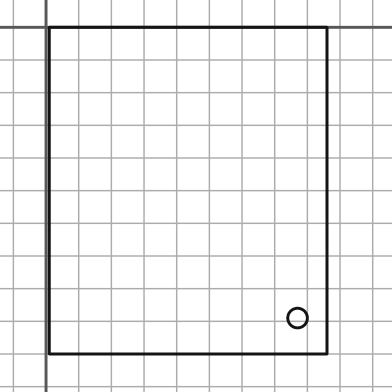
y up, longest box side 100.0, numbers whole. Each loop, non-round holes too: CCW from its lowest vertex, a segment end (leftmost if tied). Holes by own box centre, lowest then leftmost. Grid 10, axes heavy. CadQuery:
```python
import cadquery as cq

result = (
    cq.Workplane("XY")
    .moveTo(1.0, -100.0)
    .lineTo(86.0, -100.0)
    .lineTo(86.0, 0.0)
    .lineTo(1.0, 0.0)
    .close()
    .moveTo(77.0, -89.0)
    .circle(3.0)
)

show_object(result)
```